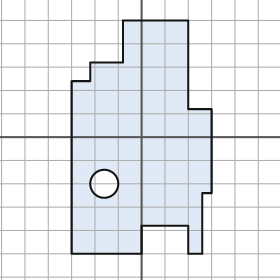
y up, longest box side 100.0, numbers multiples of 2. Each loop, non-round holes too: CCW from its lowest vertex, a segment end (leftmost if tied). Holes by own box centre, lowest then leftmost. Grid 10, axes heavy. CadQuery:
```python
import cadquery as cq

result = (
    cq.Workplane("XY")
    .moveTo(-30.0, -50.0)
    .lineTo(0.0, -50.0)
    .lineTo(0.0, -38.0)
    .lineTo(20.0, -38.0)
    .lineTo(20.0, -50.0)
    .lineTo(26.0, -50.0)
    .lineTo(26.0, -24.0)
    .lineTo(30.0, -24.0)
    .lineTo(30.0, 12.0)
    .lineTo(20.0, 12.0)
    .lineTo(20.0, 50.0)
    .lineTo(-8.0, 50.0)
    .lineTo(-8.0, 32.0)
    .lineTo(-22.0, 32.0)
    .lineTo(-22.0, 24.0)
    .lineTo(-30.0, 24.0)
    .close()
    .moveTo(-16.0, -20.0)
    .circle(6.0)
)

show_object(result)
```